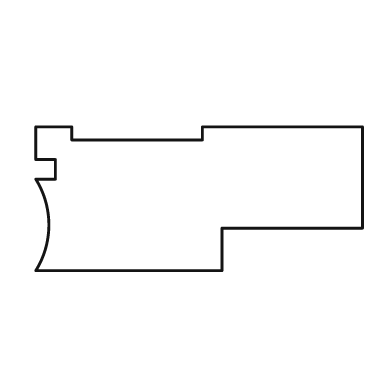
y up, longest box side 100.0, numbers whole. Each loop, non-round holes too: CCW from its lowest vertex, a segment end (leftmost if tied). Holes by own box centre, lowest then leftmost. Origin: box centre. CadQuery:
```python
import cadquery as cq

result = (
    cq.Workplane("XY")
    .moveTo(-50.0, -22.0)
    .lineTo(7.0, -22.0)
    .lineTo(7.0, -9.0)
    .lineTo(50.0, -9.0)
    .lineTo(50.0, 22.0)
    .lineTo(1.0, 22.0)
    .lineTo(1.0, 18.0)
    .lineTo(-39.0, 18.0)
    .lineTo(-39.0, 22.0)
    .lineTo(-50.0, 22.0)
    .lineTo(-50.0, 12.0)
    .lineTo(-44.0, 12.0)
    .lineTo(-44.0, 6.0)
    .lineTo(-50.0, 6.0)
    .threePointArc((-46.0, -8.0), (-50.0, -22.0))
    .close()
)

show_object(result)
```